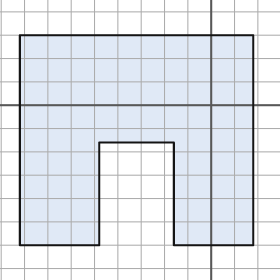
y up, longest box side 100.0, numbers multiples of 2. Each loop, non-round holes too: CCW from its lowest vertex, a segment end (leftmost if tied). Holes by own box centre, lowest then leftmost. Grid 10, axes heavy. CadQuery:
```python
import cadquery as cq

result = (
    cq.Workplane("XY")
    .moveTo(-82.0, -60.0)
    .lineTo(-48.0, -60.0)
    .lineTo(-48.0, -16.0)
    .lineTo(-16.0, -16.0)
    .lineTo(-16.0, -60.0)
    .lineTo(18.0, -60.0)
    .lineTo(18.0, 30.0)
    .lineTo(-82.0, 30.0)
    .close()
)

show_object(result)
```